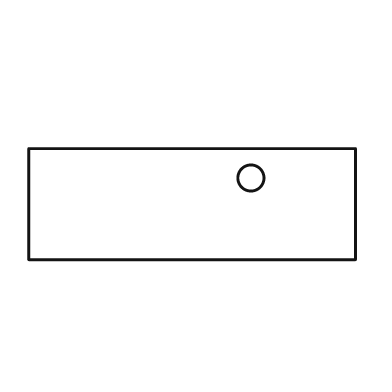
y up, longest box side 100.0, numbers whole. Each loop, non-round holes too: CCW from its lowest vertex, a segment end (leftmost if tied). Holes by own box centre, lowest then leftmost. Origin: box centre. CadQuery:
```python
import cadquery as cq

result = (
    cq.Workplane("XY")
    .moveTo(-50.0, -17.0)
    .lineTo(50.0, -17.0)
    .lineTo(50.0, 17.0)
    .lineTo(-50.0, 17.0)
    .close()
    .moveTo(18.0, 8.0)
    .circle(4.0)
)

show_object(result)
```